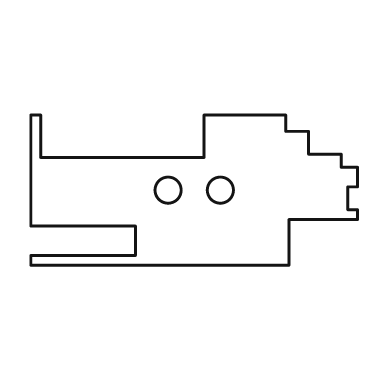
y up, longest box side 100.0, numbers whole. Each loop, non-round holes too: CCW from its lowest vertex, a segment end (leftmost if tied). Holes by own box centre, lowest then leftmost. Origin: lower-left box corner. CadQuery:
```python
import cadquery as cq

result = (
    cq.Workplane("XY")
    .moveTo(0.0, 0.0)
    .lineTo(79.0, 0.0)
    .lineTo(79.0, 14.0)
    .lineTo(100.0, 14.0)
    .lineTo(100.0, 17.0)
    .lineTo(97.0, 17.0)
    .lineTo(97.0, 24.0)
    .lineTo(100.0, 24.0)
    .lineTo(100.0, 30.0)
    .lineTo(95.0, 30.0)
    .lineTo(95.0, 34.0)
    .lineTo(85.0, 34.0)
    .lineTo(85.0, 41.0)
    .lineTo(78.0, 41.0)
    .lineTo(78.0, 46.0)
    .lineTo(53.0, 46.0)
    .lineTo(53.0, 33.0)
    .lineTo(3.0, 33.0)
    .lineTo(3.0, 46.0)
    .lineTo(0.0, 46.0)
    .lineTo(0.0, 12.0)
    .lineTo(32.0, 12.0)
    .lineTo(32.0, 3.0)
    .lineTo(0.0, 3.0)
    .close()
    .moveTo(42.0, 23.0)
    .circle(4.0)
    .moveTo(58.0, 23.0)
    .circle(4.0)
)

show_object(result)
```